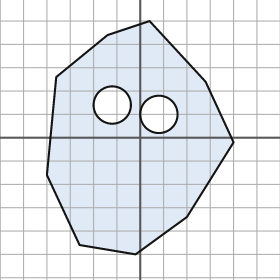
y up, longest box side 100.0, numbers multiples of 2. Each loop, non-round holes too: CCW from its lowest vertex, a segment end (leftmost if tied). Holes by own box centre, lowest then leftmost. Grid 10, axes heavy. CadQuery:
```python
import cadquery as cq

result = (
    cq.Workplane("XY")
    .moveTo(-2.0, -50.0)
    .lineTo(20.0, -34.0)
    .lineTo(40.0, -2.0)
    .lineTo(28.0, 24.0)
    .lineTo(4.0, 50.0)
    .lineTo(-14.0, 44.0)
    .lineTo(-36.0, 26.0)
    .lineTo(-40.0, -16.0)
    .lineTo(-26.0, -46.0)
    .close()
    .moveTo(8.0, 10.0)
    .circle(8.0)
    .moveTo(-12.0, 14.0)
    .circle(8.0)
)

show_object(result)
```